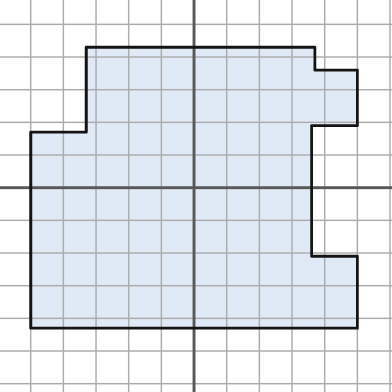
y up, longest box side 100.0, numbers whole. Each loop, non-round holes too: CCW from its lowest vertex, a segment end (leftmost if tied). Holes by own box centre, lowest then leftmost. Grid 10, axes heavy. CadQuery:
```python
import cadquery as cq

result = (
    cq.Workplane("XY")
    .moveTo(-50.0, -43.0)
    .lineTo(50.0, -43.0)
    .lineTo(50.0, -21.0)
    .lineTo(36.0, -21.0)
    .lineTo(36.0, 19.0)
    .lineTo(50.0, 19.0)
    .lineTo(50.0, 36.0)
    .lineTo(37.0, 36.0)
    .lineTo(37.0, 43.0)
    .lineTo(-33.0, 43.0)
    .lineTo(-33.0, 17.0)
    .lineTo(-50.0, 17.0)
    .close()
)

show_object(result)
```